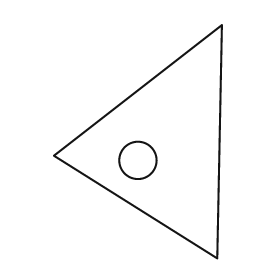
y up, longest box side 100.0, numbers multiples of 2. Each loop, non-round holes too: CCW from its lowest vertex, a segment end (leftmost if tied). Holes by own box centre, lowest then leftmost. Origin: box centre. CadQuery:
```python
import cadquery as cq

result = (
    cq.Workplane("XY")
    .moveTo(34.0, -50.0)
    .lineTo(36.0, 50.0)
    .lineTo(-36.0, -6.0)
    .close()
    .moveTo(0.0, -8.0)
    .circle(8.0)
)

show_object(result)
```